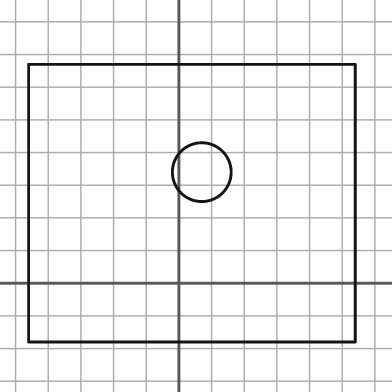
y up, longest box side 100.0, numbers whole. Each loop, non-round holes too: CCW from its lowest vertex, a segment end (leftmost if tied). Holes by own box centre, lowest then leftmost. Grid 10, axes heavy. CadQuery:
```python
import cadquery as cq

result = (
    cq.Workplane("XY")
    .moveTo(-46.0, -18.0)
    .lineTo(54.0, -18.0)
    .lineTo(54.0, 67.0)
    .lineTo(-46.0, 67.0)
    .close()
    .moveTo(7.0, 34.0)
    .circle(9.0)
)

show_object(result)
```